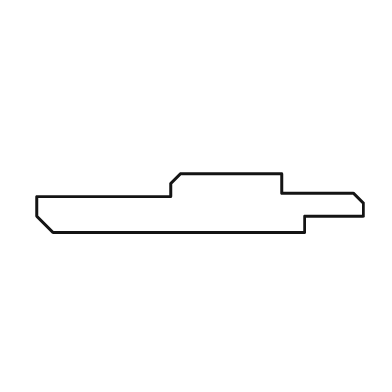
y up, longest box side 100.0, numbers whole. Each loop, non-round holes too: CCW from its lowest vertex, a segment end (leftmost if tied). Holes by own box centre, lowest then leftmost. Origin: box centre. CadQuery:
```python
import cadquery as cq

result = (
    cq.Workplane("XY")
    .moveTo(-45.0, -9.0)
    .lineTo(32.0, -9.0)
    .lineTo(32.0, -4.0)
    .lineTo(50.0, -4.0)
    .lineTo(50.0, 0.0)
    .lineTo(47.0, 3.0)
    .lineTo(25.0, 3.0)
    .lineTo(25.0, 9.0)
    .lineTo(-6.0, 9.0)
    .lineTo(-9.0, 6.0)
    .lineTo(-9.0, 2.0)
    .lineTo(-50.0, 2.0)
    .lineTo(-50.0, -4.0)
    .close()
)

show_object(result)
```